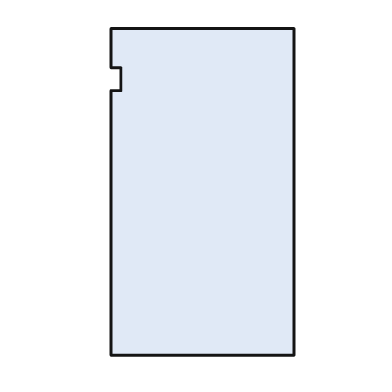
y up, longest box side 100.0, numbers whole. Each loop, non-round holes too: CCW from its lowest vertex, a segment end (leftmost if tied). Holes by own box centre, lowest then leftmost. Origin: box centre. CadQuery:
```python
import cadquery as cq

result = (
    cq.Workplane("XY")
    .moveTo(-28.0, -50.0)
    .lineTo(28.0, -50.0)
    .lineTo(28.0, 50.0)
    .lineTo(-28.0, 50.0)
    .lineTo(-28.0, 38.0)
    .lineTo(-25.0, 38.0)
    .lineTo(-25.0, 31.0)
    .lineTo(-28.0, 31.0)
    .close()
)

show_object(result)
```